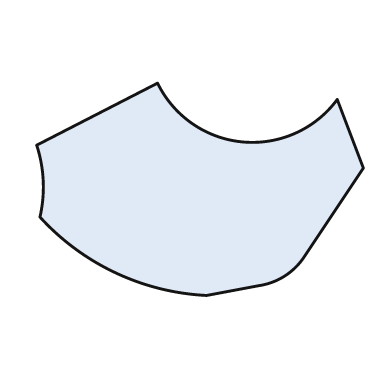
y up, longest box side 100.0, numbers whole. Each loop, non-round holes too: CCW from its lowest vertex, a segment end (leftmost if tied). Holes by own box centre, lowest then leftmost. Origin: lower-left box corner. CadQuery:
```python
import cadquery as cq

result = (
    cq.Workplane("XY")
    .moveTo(52.0, 0.0)
    .lineTo(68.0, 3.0)
    .threePointArc((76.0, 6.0), (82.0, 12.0))
    .lineTo(100.0, 39.0)
    .lineTo(92.0, 60.0)
    .threePointArc((63.0, 47.0), (37.0, 65.0))
    .lineTo(0.0, 46.0)
    .threePointArc((2.0, 35.0), (1.0, 24.0))
    .threePointArc((24.0, 7.0), (52.0, 0.0))
    .close()
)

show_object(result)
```